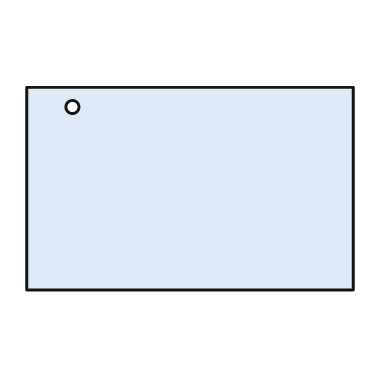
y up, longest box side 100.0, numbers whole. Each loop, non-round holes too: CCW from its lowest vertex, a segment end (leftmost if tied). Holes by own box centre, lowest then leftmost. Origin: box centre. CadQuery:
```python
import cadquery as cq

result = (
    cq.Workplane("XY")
    .moveTo(-50.0, -31.0)
    .lineTo(50.0, -31.0)
    .lineTo(50.0, 31.0)
    .lineTo(-50.0, 31.0)
    .close()
    .moveTo(-36.0, 25.0)
    .circle(2.0)
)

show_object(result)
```